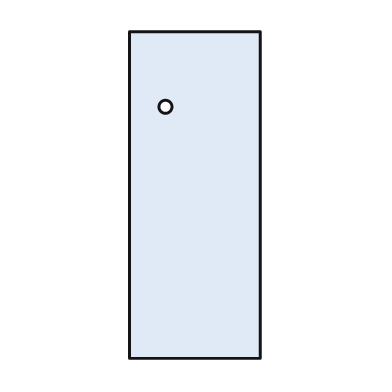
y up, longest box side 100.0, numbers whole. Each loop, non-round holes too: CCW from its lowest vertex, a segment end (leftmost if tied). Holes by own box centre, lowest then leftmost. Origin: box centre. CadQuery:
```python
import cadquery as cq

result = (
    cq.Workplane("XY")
    .moveTo(-20.0, -50.0)
    .lineTo(20.0, -50.0)
    .lineTo(20.0, 50.0)
    .lineTo(-20.0, 50.0)
    .close()
    .moveTo(-9.0, 27.0)
    .circle(2.0)
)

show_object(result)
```